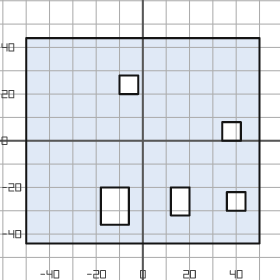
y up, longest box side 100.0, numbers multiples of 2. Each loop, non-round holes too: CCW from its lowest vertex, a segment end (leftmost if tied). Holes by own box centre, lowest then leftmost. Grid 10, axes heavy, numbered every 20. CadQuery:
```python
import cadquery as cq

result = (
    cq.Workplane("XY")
    .moveTo(-50.0, -44.0)
    .lineTo(50.0, -44.0)
    .lineTo(50.0, 44.0)
    .lineTo(-50.0, 44.0)
    .close()
    .moveTo(-18.0, -36.0)
    .lineTo(-6.0, -36.0)
    .lineTo(-6.0, -20.0)
    .lineTo(-18.0, -20.0)
    .close()
    .moveTo(12.0, -32.0)
    .lineTo(20.0, -32.0)
    .lineTo(20.0, -20.0)
    .lineTo(12.0, -20.0)
    .close()
    .moveTo(36.0, -30.0)
    .lineTo(44.0, -30.0)
    .lineTo(44.0, -22.0)
    .lineTo(36.0, -22.0)
    .close()
    .moveTo(34.0, 0.0)
    .lineTo(42.0, 0.0)
    .lineTo(42.0, 8.0)
    .lineTo(34.0, 8.0)
    .close()
    .moveTo(-10.0, 20.0)
    .lineTo(-2.0, 20.0)
    .lineTo(-2.0, 28.0)
    .lineTo(-10.0, 28.0)
    .close()
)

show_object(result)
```